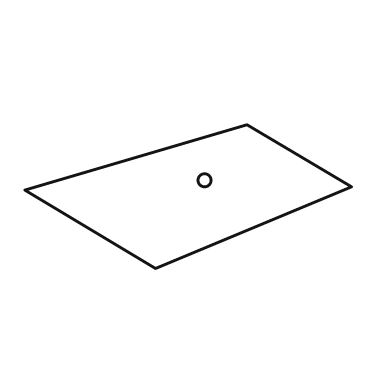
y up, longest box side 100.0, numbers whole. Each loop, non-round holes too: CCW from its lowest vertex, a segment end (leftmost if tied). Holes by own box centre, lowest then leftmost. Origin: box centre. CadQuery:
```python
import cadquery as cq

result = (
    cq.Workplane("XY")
    .moveTo(-10.0, -22.0)
    .lineTo(50.0, 3.0)
    .lineTo(18.0, 22.0)
    .lineTo(-50.0, 2.0)
    .close()
    .moveTo(5.0, 5.0)
    .circle(2.0)
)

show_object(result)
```